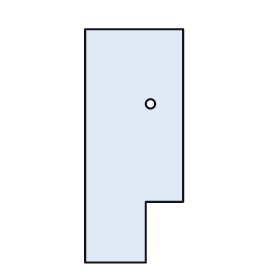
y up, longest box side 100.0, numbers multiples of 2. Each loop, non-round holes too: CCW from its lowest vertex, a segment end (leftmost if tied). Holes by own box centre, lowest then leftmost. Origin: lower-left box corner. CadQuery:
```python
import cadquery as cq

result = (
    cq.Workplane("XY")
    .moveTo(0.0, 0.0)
    .lineTo(26.0, 0.0)
    .lineTo(26.0, 26.0)
    .lineTo(42.0, 26.0)
    .lineTo(42.0, 100.0)
    .lineTo(0.0, 100.0)
    .close()
    .moveTo(28.0, 68.0)
    .circle(2.0)
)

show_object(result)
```